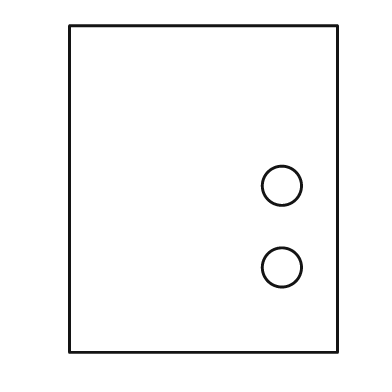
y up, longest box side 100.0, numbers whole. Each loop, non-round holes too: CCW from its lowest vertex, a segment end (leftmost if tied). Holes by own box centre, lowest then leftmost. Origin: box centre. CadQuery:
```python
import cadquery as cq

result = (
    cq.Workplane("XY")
    .moveTo(-41.0, -50.0)
    .lineTo(41.0, -50.0)
    .lineTo(41.0, 50.0)
    .lineTo(-41.0, 50.0)
    .close()
    .moveTo(24.0, -24.0)
    .circle(6.0)
    .moveTo(24.0, 1.0)
    .circle(6.0)
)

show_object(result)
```